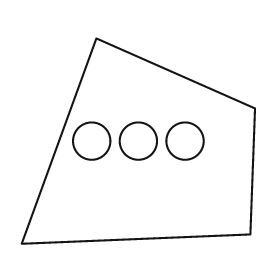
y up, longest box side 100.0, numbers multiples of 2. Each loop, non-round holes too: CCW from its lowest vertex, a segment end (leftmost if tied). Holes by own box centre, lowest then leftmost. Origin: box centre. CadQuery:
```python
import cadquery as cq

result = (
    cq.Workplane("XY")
    .moveTo(-50.0, -44.0)
    .lineTo(48.0, -40.0)
    .lineTo(50.0, 14.0)
    .lineTo(-18.0, 44.0)
    .close()
    .moveTo(-20.0, 0.0)
    .circle(8.0)
    .moveTo(0.0, 0.0)
    .circle(8.0)
    .moveTo(20.0, 0.0)
    .circle(8.0)
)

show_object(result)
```